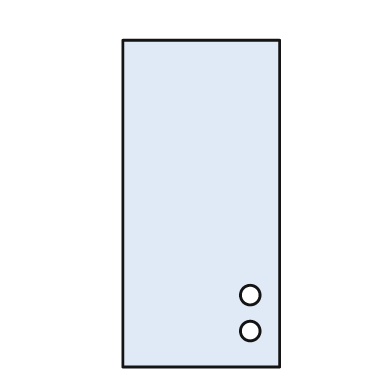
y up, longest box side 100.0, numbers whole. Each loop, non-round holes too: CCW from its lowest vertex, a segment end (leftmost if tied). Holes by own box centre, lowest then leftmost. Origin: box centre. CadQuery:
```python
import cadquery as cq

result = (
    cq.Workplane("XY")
    .moveTo(-24.0, -50.0)
    .lineTo(24.0, -50.0)
    .lineTo(24.0, 50.0)
    .lineTo(-24.0, 50.0)
    .close()
    .moveTo(15.0, -39.0)
    .circle(3.0)
    .moveTo(15.0, -28.0)
    .circle(3.0)
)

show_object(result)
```